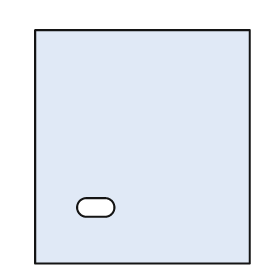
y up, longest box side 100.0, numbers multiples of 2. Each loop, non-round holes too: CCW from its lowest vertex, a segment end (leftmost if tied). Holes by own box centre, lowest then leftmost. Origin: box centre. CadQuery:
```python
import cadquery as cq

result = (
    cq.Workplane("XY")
    .moveTo(-46.0, -50.0)
    .lineTo(46.0, -50.0)
    .lineTo(46.0, 50.0)
    .lineTo(-46.0, 50.0)
    .close()
    .moveTo(-24.0, -30.0)
    .lineTo(-16.0, -30.0)
    .threePointArc((-12.0, -26.0), (-16.0, -22.0))
    .lineTo(-24.0, -22.0)
    .threePointArc((-28.0, -26.0), (-24.0, -30.0))
    .close()
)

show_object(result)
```